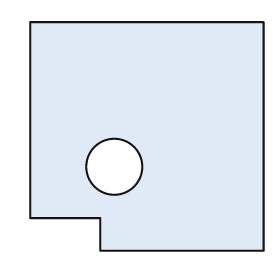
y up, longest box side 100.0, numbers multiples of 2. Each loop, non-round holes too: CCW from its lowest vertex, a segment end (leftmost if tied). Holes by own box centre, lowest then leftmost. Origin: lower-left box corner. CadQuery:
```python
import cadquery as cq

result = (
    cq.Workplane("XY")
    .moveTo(30.0, 0.0)
    .lineTo(100.0, 0.0)
    .lineTo(100.0, 98.0)
    .lineTo(0.0, 98.0)
    .lineTo(0.0, 14.0)
    .lineTo(30.0, 14.0)
    .close()
    .moveTo(36.0, 36.0)
    .circle(12.0)
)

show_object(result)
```